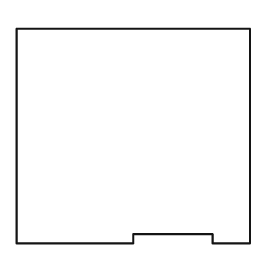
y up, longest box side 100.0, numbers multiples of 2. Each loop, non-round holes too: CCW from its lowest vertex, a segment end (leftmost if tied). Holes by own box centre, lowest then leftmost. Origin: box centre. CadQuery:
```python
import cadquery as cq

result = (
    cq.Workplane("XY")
    .moveTo(-50.0, -46.0)
    .lineTo(0.0, -46.0)
    .lineTo(0.0, -42.0)
    .lineTo(34.0, -42.0)
    .lineTo(34.0, -46.0)
    .lineTo(50.0, -46.0)
    .lineTo(50.0, 46.0)
    .lineTo(-50.0, 46.0)
    .close()
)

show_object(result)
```